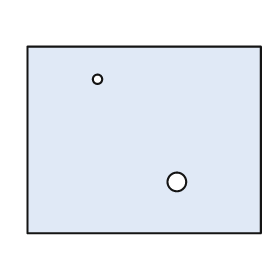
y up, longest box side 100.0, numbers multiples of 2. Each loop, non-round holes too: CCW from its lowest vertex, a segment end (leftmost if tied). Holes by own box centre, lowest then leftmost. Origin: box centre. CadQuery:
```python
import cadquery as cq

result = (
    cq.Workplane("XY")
    .moveTo(-50.0, -40.0)
    .lineTo(50.0, -40.0)
    .lineTo(50.0, 40.0)
    .lineTo(-50.0, 40.0)
    .close()
    .moveTo(14.0, -18.0)
    .circle(4.0)
    .moveTo(-20.0, 26.0)
    .circle(2.0)
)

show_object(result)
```